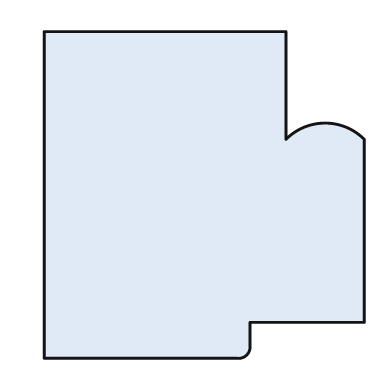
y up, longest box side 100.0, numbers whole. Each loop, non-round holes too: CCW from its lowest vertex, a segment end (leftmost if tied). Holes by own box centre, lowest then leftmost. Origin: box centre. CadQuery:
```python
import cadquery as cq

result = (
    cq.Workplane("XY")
    .moveTo(-49.0, -50.0)
    .lineTo(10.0, -50.0)
    .threePointArc((13.0, -49.0), (14.0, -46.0))
    .lineTo(14.0, -39.0)
    .lineTo(49.0, -39.0)
    .lineTo(49.0, 17.0)
    .threePointArc((37.0, 22.0), (25.0, 17.0))
    .lineTo(25.0, 50.0)
    .lineTo(-49.0, 50.0)
    .close()
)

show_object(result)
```